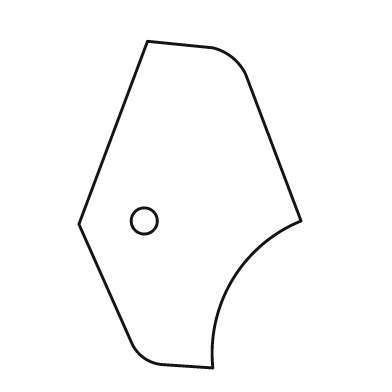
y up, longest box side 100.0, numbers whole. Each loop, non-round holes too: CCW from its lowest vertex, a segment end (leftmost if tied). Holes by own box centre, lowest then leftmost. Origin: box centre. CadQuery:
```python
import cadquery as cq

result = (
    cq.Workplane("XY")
    .moveTo(7.0, -50.0)
    .threePointArc((13.0, -23.0), (34.0, -5.0))
    .lineTo(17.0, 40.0)
    .threePointArc((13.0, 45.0), (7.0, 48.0))
    .lineTo(-13.0, 50.0)
    .lineTo(-34.0, -6.0)
    .lineTo(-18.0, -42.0)
    .threePointArc((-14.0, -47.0), (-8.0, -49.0))
    .close()
    .moveTo(-14.0, -5.0)
    .circle(4.0)
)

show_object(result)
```